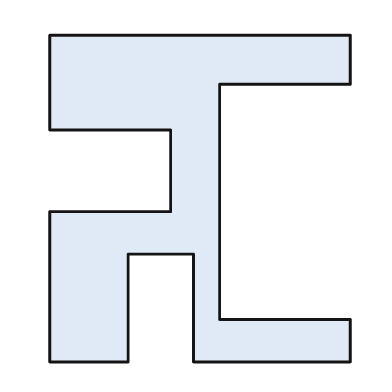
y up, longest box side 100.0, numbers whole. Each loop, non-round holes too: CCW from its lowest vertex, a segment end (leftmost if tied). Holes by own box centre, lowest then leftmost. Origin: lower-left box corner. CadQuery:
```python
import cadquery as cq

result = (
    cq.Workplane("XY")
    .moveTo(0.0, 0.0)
    .lineTo(24.0, 0.0)
    .lineTo(24.0, 33.0)
    .lineTo(44.0, 33.0)
    .lineTo(44.0, 0.0)
    .lineTo(92.0, 0.0)
    .lineTo(92.0, 13.0)
    .lineTo(52.0, 13.0)
    .lineTo(52.0, 85.0)
    .lineTo(92.0, 85.0)
    .lineTo(92.0, 100.0)
    .lineTo(0.0, 100.0)
    .lineTo(0.0, 71.0)
    .lineTo(37.0, 71.0)
    .lineTo(37.0, 46.0)
    .lineTo(0.0, 46.0)
    .close()
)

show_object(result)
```